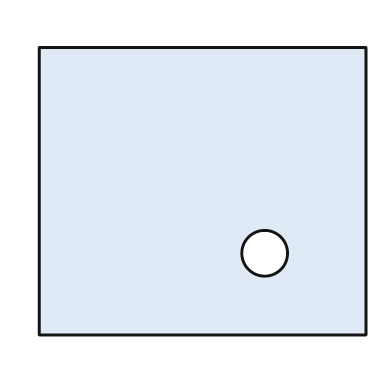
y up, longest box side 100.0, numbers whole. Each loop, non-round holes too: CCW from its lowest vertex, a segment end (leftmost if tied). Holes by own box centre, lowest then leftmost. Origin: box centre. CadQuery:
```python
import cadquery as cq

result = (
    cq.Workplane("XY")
    .moveTo(-50.0, -44.0)
    .lineTo(50.0, -44.0)
    .lineTo(50.0, 44.0)
    .lineTo(-50.0, 44.0)
    .close()
    .moveTo(19.0, -19.0)
    .circle(7.0)
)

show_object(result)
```